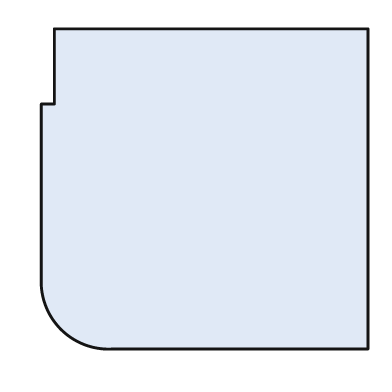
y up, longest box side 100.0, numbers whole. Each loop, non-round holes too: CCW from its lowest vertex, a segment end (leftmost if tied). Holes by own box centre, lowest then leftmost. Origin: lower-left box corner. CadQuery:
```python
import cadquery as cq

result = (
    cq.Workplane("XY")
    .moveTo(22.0, 0.0)
    .lineTo(100.0, 0.0)
    .lineTo(100.0, 98.0)
    .lineTo(4.0, 98.0)
    .lineTo(4.0, 75.0)
    .lineTo(0.0, 75.0)
    .lineTo(0.0, 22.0)
    .threePointArc((6.0, 6.0), (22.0, 0.0))
    .close()
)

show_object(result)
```